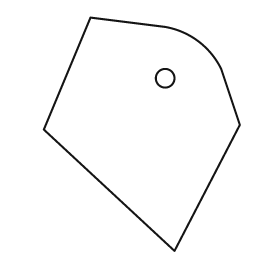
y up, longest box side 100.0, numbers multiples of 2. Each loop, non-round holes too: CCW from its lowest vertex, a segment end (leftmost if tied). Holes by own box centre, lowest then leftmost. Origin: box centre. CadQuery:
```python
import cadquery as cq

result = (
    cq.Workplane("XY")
    .moveTo(14.0, -50.0)
    .lineTo(42.0, 4.0)
    .lineTo(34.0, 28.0)
    .threePointArc((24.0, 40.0), (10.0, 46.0))
    .lineTo(-22.0, 50.0)
    .lineTo(-42.0, 2.0)
    .close()
    .moveTo(10.0, 24.0)
    .circle(4.0)
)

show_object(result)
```